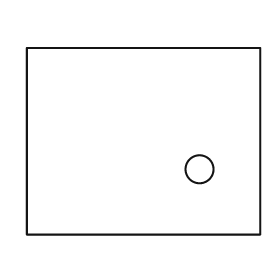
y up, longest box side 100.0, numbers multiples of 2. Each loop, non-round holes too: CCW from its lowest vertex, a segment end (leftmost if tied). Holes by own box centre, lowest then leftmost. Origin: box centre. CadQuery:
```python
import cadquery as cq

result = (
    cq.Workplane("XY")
    .moveTo(-50.0, -40.0)
    .lineTo(50.0, -40.0)
    .lineTo(50.0, 40.0)
    .lineTo(-50.0, 40.0)
    .close()
    .moveTo(24.0, -12.0)
    .circle(6.0)
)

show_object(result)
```